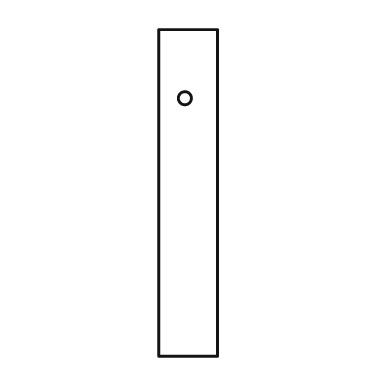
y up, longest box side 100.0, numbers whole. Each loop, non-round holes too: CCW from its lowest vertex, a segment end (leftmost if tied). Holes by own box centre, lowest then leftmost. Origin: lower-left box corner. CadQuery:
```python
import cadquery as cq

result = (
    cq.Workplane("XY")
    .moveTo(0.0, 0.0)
    .lineTo(18.0, 0.0)
    .lineTo(18.0, 100.0)
    .lineTo(0.0, 100.0)
    .close()
    .moveTo(8.0, 79.0)
    .circle(2.0)
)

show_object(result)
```